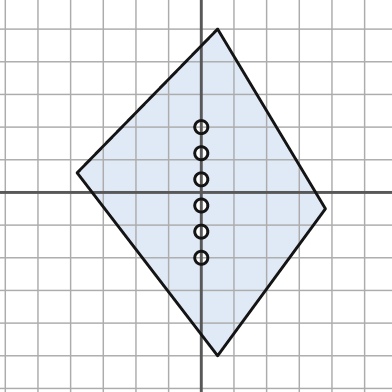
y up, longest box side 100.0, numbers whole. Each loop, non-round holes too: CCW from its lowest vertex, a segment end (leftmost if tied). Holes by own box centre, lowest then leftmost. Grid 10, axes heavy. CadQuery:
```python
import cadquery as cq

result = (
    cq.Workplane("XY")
    .moveTo(5.0, -50.0)
    .lineTo(38.0, -5.0)
    .lineTo(5.0, 50.0)
    .lineTo(-38.0, 6.0)
    .close()
    .moveTo(0.0, -20.0)
    .circle(2.0)
    .moveTo(0.0, -12.0)
    .circle(2.0)
    .moveTo(0.0, -4.0)
    .circle(2.0)
    .moveTo(0.0, 4.0)
    .circle(2.0)
    .moveTo(0.0, 12.0)
    .circle(2.0)
    .moveTo(0.0, 20.0)
    .circle(2.0)
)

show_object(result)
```